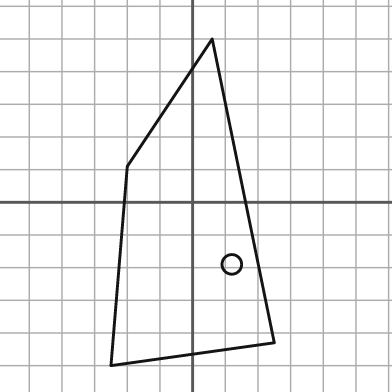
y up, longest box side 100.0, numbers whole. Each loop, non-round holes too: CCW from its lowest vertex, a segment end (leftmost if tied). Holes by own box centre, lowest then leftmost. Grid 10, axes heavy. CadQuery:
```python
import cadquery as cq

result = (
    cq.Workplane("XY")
    .moveTo(-25.0, -50.0)
    .lineTo(25.0, -43.0)
    .lineTo(6.0, 50.0)
    .lineTo(-20.0, 11.0)
    .close()
    .moveTo(12.0, -19.0)
    .circle(3.0)
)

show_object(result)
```